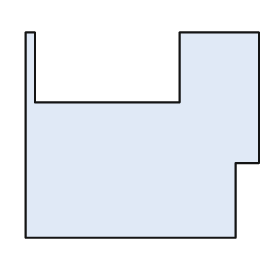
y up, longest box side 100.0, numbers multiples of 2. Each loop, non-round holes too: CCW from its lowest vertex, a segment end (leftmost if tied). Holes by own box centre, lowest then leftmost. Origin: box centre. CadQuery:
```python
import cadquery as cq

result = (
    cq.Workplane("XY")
    .moveTo(-50.0, -44.0)
    .lineTo(40.0, -44.0)
    .lineTo(40.0, -12.0)
    .lineTo(50.0, -12.0)
    .lineTo(50.0, 44.0)
    .lineTo(16.0, 44.0)
    .lineTo(16.0, 14.0)
    .lineTo(-46.0, 14.0)
    .lineTo(-46.0, 44.0)
    .lineTo(-50.0, 44.0)
    .close()
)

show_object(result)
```